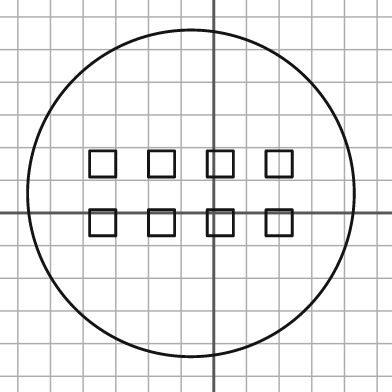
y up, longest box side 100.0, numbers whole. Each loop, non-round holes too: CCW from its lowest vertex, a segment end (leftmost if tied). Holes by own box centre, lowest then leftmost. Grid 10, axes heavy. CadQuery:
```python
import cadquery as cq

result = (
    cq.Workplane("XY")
    .moveTo(-7.0, 6.0)
    .circle(50.0)
    .moveTo(-38.0, -7.0)
    .lineTo(-30.0, -7.0)
    .lineTo(-30.0, 1.0)
    .lineTo(-38.0, 1.0)
    .close()
    .moveTo(-20.0, -7.0)
    .lineTo(-12.0, -7.0)
    .lineTo(-12.0, 1.0)
    .lineTo(-20.0, 1.0)
    .close()
    .moveTo(-2.0, -7.0)
    .lineTo(6.0, -7.0)
    .lineTo(6.0, 1.0)
    .lineTo(-2.0, 1.0)
    .close()
    .moveTo(16.0, -7.0)
    .lineTo(24.0, -7.0)
    .lineTo(24.0, 1.0)
    .lineTo(16.0, 1.0)
    .close()
    .moveTo(-38.0, 11.0)
    .lineTo(-30.0, 11.0)
    .lineTo(-30.0, 19.0)
    .lineTo(-38.0, 19.0)
    .close()
    .moveTo(-20.0, 11.0)
    .lineTo(-12.0, 11.0)
    .lineTo(-12.0, 19.0)
    .lineTo(-20.0, 19.0)
    .close()
    .moveTo(-2.0, 11.0)
    .lineTo(6.0, 11.0)
    .lineTo(6.0, 19.0)
    .lineTo(-2.0, 19.0)
    .close()
    .moveTo(16.0, 11.0)
    .lineTo(24.0, 11.0)
    .lineTo(24.0, 19.0)
    .lineTo(16.0, 19.0)
    .close()
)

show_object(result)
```